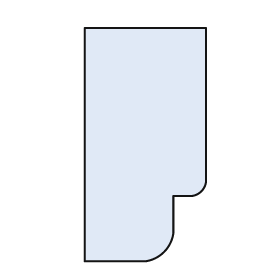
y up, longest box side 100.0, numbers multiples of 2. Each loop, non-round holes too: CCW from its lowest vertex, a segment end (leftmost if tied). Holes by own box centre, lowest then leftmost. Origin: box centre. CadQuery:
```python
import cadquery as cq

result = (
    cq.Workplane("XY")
    .moveTo(-26.0, -50.0)
    .lineTo(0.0, -50.0)
    .threePointArc((8.0, -46.0), (12.0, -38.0))
    .lineTo(12.0, -22.0)
    .lineTo(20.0, -22.0)
    .threePointArc((24.0, -20.0), (26.0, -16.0))
    .lineTo(26.0, 50.0)
    .lineTo(-26.0, 50.0)
    .close()
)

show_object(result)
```